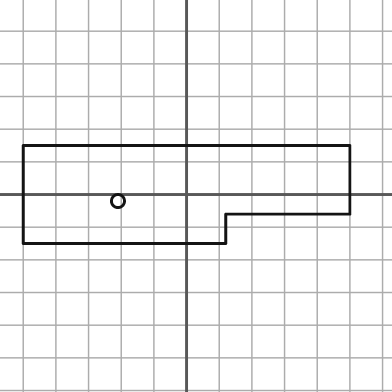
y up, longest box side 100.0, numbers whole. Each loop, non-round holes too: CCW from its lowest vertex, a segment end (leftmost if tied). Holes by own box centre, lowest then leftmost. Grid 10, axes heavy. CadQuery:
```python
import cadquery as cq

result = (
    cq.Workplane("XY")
    .moveTo(-50.0, -15.0)
    .lineTo(12.0, -15.0)
    .lineTo(12.0, -6.0)
    .lineTo(50.0, -6.0)
    .lineTo(50.0, 15.0)
    .lineTo(-50.0, 15.0)
    .close()
    .moveTo(-21.0, -2.0)
    .circle(2.0)
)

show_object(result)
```